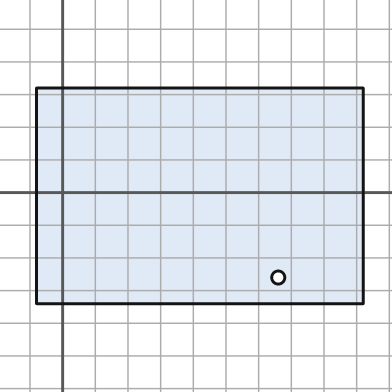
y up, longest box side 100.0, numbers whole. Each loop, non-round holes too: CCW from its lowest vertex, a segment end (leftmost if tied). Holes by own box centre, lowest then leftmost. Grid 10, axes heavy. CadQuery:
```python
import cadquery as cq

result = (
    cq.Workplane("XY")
    .moveTo(-8.0, -34.0)
    .lineTo(92.0, -34.0)
    .lineTo(92.0, 32.0)
    .lineTo(-8.0, 32.0)
    .close()
    .moveTo(66.0, -26.0)
    .circle(2.0)
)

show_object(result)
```